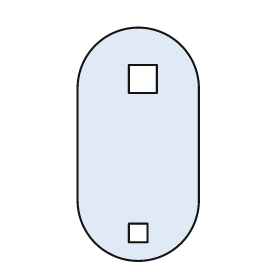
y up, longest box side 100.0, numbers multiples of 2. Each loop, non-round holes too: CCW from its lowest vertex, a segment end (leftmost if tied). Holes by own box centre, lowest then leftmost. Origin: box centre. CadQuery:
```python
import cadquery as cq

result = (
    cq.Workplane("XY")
    .moveTo(-26.0, -24.0)
    .threePointArc((0.0, -50.0), (26.0, -24.0))
    .lineTo(26.0, 24.0)
    .threePointArc((0.0, 50.0), (-26.0, 24.0))
    .close()
    .moveTo(-4.0, -42.0)
    .lineTo(4.0, -42.0)
    .lineTo(4.0, -34.0)
    .lineTo(-4.0, -34.0)
    .close()
    .moveTo(-4.0, 22.0)
    .lineTo(8.0, 22.0)
    .lineTo(8.0, 34.0)
    .lineTo(-4.0, 34.0)
    .close()
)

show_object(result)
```